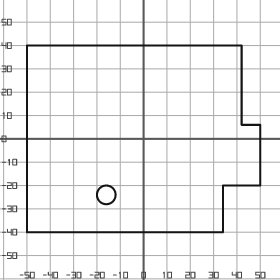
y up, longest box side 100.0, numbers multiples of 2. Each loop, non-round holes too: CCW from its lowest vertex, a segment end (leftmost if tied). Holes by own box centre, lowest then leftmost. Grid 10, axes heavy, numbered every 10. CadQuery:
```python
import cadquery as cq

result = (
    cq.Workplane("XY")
    .moveTo(-50.0, -40.0)
    .lineTo(34.0, -40.0)
    .lineTo(34.0, -20.0)
    .lineTo(50.0, -20.0)
    .lineTo(50.0, 6.0)
    .lineTo(42.0, 6.0)
    .lineTo(42.0, 40.0)
    .lineTo(-50.0, 40.0)
    .close()
    .moveTo(-16.0, -24.0)
    .circle(4.0)
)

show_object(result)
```